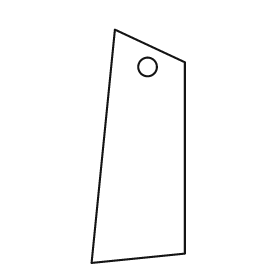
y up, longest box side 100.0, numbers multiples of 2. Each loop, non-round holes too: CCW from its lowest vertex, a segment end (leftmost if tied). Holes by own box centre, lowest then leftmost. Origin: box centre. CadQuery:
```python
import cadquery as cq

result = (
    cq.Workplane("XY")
    .moveTo(-20.0, -50.0)
    .lineTo(20.0, -46.0)
    .lineTo(20.0, 36.0)
    .lineTo(-10.0, 50.0)
    .close()
    .moveTo(4.0, 34.0)
    .circle(4.0)
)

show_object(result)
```